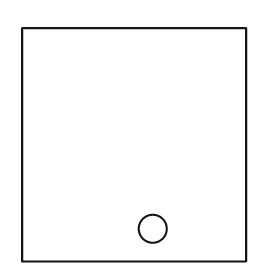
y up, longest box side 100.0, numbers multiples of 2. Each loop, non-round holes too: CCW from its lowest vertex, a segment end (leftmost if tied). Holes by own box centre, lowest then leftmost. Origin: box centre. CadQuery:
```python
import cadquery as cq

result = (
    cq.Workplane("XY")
    .moveTo(-48.0, -50.0)
    .lineTo(48.0, -50.0)
    .lineTo(48.0, 50.0)
    .lineTo(-48.0, 50.0)
    .close()
    .moveTo(8.0, -36.0)
    .circle(6.0)
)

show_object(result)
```